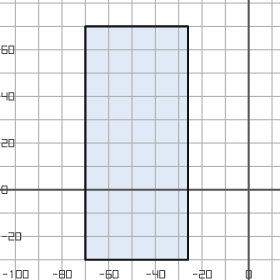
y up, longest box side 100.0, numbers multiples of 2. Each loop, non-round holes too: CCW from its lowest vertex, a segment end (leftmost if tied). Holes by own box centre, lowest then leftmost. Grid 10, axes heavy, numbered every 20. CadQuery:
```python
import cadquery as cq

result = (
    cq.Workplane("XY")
    .moveTo(-70.0, -30.0)
    .lineTo(-26.0, -30.0)
    .lineTo(-26.0, 70.0)
    .lineTo(-70.0, 70.0)
    .close()
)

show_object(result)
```